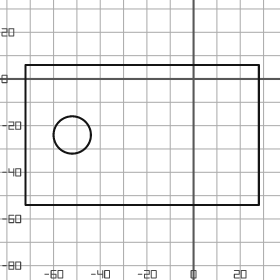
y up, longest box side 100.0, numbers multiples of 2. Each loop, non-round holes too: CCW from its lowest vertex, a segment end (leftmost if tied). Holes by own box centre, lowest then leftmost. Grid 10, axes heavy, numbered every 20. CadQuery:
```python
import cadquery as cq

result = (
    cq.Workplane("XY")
    .moveTo(-72.0, -54.0)
    .lineTo(28.0, -54.0)
    .lineTo(28.0, 6.0)
    .lineTo(-72.0, 6.0)
    .close()
    .moveTo(-52.0, -24.0)
    .circle(8.0)
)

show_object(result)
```